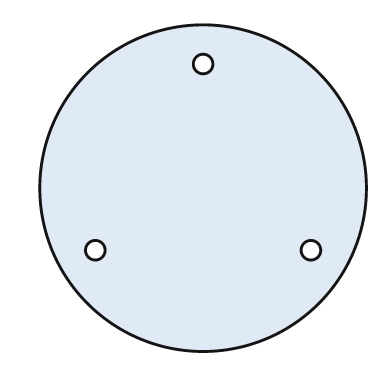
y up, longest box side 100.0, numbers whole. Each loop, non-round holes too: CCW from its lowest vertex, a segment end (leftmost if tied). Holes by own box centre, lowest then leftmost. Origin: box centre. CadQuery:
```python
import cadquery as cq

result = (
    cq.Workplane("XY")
    .moveTo(0.0, 0.0)
    .circle(50.0)
    .moveTo(-33.0, -19.0)
    .circle(3.0)
    .moveTo(33.0, -19.0)
    .circle(3.0)
    .moveTo(0.0, 38.0)
    .circle(3.0)
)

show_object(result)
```